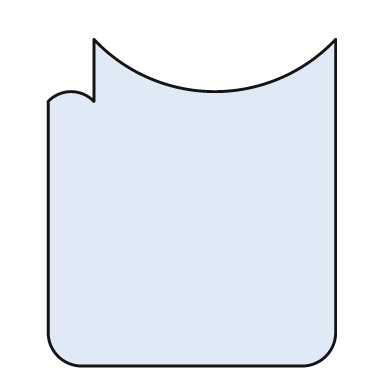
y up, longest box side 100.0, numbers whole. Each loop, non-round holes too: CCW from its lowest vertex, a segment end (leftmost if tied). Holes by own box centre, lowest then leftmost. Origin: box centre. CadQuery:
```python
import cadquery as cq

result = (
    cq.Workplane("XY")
    .moveTo(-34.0, -50.0)
    .lineTo(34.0, -50.0)
    .threePointArc((41.0, -47.0), (44.0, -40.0))
    .lineTo(44.0, 50.0)
    .threePointArc((7.0, 34.0), (-30.0, 50.0))
    .lineTo(-30.0, 31.0)
    .threePointArc((-37.0, 34.0), (-44.0, 31.0))
    .lineTo(-44.0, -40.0)
    .threePointArc((-41.0, -47.0), (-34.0, -50.0))
    .close()
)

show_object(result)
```